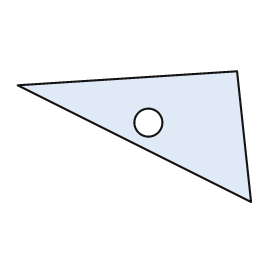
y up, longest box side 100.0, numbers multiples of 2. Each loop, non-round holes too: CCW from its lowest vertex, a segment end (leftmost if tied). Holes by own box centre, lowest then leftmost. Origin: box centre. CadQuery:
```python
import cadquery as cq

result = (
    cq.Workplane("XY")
    .moveTo(50.0, -28.0)
    .lineTo(44.0, 28.0)
    .lineTo(-50.0, 22.0)
    .close()
    .moveTo(6.0, 6.0)
    .circle(6.0)
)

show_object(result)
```